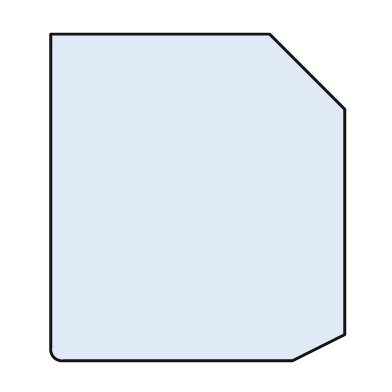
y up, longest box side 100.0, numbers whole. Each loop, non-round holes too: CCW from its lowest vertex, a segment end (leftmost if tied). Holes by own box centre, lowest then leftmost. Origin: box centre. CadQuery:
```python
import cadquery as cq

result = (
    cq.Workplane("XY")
    .moveTo(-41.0, -50.0)
    .lineTo(29.0, -50.0)
    .lineTo(45.0, -42.0)
    .lineTo(45.0, 27.0)
    .lineTo(22.0, 50.0)
    .lineTo(-45.0, 50.0)
    .lineTo(-45.0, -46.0)
    .threePointArc((-44.0, -49.0), (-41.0, -50.0))
    .close()
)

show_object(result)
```